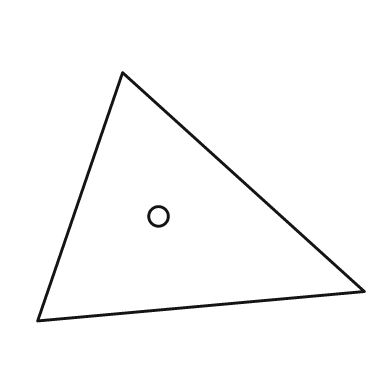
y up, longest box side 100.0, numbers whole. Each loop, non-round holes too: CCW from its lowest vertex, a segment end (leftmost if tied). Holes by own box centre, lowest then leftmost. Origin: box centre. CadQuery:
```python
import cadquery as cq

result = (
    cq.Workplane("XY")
    .moveTo(-50.0, -38.0)
    .lineTo(50.0, -29.0)
    .lineTo(-24.0, 38.0)
    .close()
    .moveTo(-13.0, -6.0)
    .circle(3.0)
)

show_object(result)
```